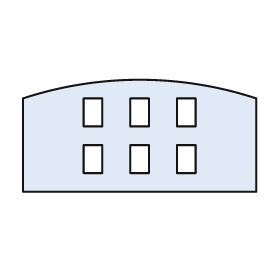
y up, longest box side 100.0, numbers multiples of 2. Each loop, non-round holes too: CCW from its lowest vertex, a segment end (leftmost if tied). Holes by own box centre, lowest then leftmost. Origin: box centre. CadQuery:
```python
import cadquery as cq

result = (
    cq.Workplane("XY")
    .moveTo(-50.0, -24.0)
    .lineTo(50.0, -24.0)
    .lineTo(50.0, 16.0)
    .threePointArc((0.0, 24.0), (-50.0, 16.0))
    .close()
    .moveTo(-24.0, -16.0)
    .lineTo(-16.0, -16.0)
    .lineTo(-16.0, -4.0)
    .lineTo(-24.0, -4.0)
    .close()
    .moveTo(-4.0, -16.0)
    .lineTo(4.0, -16.0)
    .lineTo(4.0, -4.0)
    .lineTo(-4.0, -4.0)
    .close()
    .moveTo(16.0, -16.0)
    .lineTo(24.0, -16.0)
    .lineTo(24.0, -4.0)
    .lineTo(16.0, -4.0)
    .close()
    .moveTo(-24.0, 4.0)
    .lineTo(-16.0, 4.0)
    .lineTo(-16.0, 16.0)
    .lineTo(-24.0, 16.0)
    .close()
    .moveTo(-4.0, 4.0)
    .lineTo(4.0, 4.0)
    .lineTo(4.0, 16.0)
    .lineTo(-4.0, 16.0)
    .close()
    .moveTo(16.0, 4.0)
    .lineTo(24.0, 4.0)
    .lineTo(24.0, 16.0)
    .lineTo(16.0, 16.0)
    .close()
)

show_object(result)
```